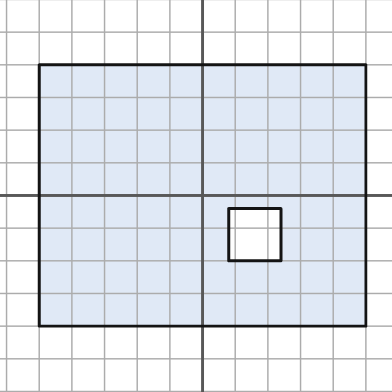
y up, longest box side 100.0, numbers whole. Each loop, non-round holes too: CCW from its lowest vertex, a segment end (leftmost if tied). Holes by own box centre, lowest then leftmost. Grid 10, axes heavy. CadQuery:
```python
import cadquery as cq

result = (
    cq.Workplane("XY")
    .moveTo(-50.0, -40.0)
    .lineTo(50.0, -40.0)
    .lineTo(50.0, 40.0)
    .lineTo(-50.0, 40.0)
    .close()
    .moveTo(8.0, -20.0)
    .lineTo(24.0, -20.0)
    .lineTo(24.0, -4.0)
    .lineTo(8.0, -4.0)
    .close()
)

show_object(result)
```